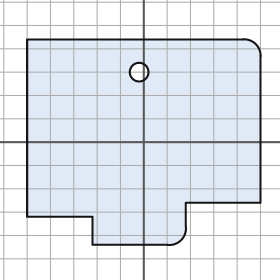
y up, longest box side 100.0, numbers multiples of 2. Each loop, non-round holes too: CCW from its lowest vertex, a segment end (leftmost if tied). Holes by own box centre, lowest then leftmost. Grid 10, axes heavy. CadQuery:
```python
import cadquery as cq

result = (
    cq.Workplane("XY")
    .moveTo(-22.0, -44.0)
    .lineTo(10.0, -44.0)
    .threePointArc((16.0, -42.0), (18.0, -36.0))
    .lineTo(18.0, -26.0)
    .lineTo(50.0, -26.0)
    .lineTo(50.0, 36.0)
    .threePointArc((48.0, 42.0), (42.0, 44.0))
    .lineTo(-50.0, 44.0)
    .lineTo(-50.0, -32.0)
    .lineTo(-22.0, -32.0)
    .close()
    .moveTo(-2.0, 30.0)
    .circle(4.0)
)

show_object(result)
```